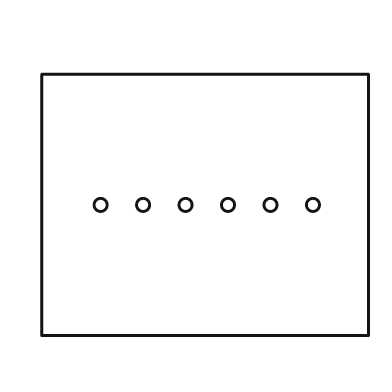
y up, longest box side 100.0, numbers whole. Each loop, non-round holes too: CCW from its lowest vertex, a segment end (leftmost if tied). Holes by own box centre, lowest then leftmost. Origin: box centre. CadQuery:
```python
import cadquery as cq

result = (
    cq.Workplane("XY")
    .moveTo(-50.0, -40.0)
    .lineTo(50.0, -40.0)
    .lineTo(50.0, 40.0)
    .lineTo(-50.0, 40.0)
    .close()
    .moveTo(-32.0, 0.0)
    .circle(2.0)
    .moveTo(-19.0, 0.0)
    .circle(2.0)
    .moveTo(-6.0, 0.0)
    .circle(2.0)
    .moveTo(7.0, 0.0)
    .circle(2.0)
    .moveTo(20.0, 0.0)
    .circle(2.0)
    .moveTo(33.0, 0.0)
    .circle(2.0)
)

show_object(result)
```